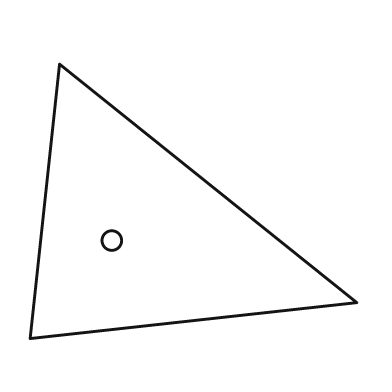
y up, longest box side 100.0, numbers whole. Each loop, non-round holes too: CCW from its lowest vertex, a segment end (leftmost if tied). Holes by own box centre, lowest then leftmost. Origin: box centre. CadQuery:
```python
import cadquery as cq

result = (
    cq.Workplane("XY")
    .moveTo(-50.0, -42.0)
    .lineTo(50.0, -31.0)
    .lineTo(-41.0, 42.0)
    .close()
    .moveTo(-25.0, -12.0)
    .circle(3.0)
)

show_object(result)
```